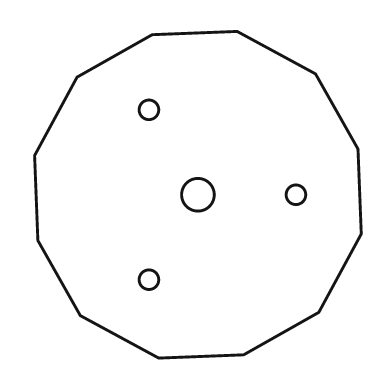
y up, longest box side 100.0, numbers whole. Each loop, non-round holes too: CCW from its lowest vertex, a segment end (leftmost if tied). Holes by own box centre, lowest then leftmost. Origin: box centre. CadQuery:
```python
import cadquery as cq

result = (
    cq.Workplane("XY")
    .moveTo(-12.0, -50.0)
    .lineTo(14.0, -49.0)
    .lineTo(37.0, -36.0)
    .lineTo(50.0, -12.0)
    .lineTo(49.0, 14.0)
    .lineTo(36.0, 37.0)
    .lineTo(12.0, 50.0)
    .lineTo(-14.0, 49.0)
    .lineTo(-37.0, 36.0)
    .lineTo(-50.0, 12.0)
    .lineTo(-49.0, -14.0)
    .lineTo(-36.0, -37.0)
    .close()
    .moveTo(-15.0, -26.0)
    .circle(3.0)
    .moveTo(0.0, 0.0)
    .circle(5.0)
    .moveTo(30.0, 0.0)
    .circle(3.0)
    .moveTo(-15.0, 26.0)
    .circle(3.0)
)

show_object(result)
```